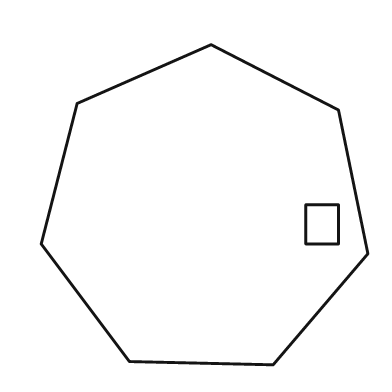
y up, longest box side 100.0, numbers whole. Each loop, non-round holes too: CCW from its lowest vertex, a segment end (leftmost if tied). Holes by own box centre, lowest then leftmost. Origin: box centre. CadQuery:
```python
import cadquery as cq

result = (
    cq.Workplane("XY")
    .moveTo(21.0, -49.0)
    .lineTo(50.0, -15.0)
    .lineTo(41.0, 29.0)
    .lineTo(2.0, 49.0)
    .lineTo(-39.0, 31.0)
    .lineTo(-50.0, -12.0)
    .lineTo(-23.0, -48.0)
    .close()
    .moveTo(31.0, -12.0)
    .lineTo(41.0, -12.0)
    .lineTo(41.0, 0.0)
    .lineTo(31.0, 0.0)
    .close()
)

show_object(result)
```